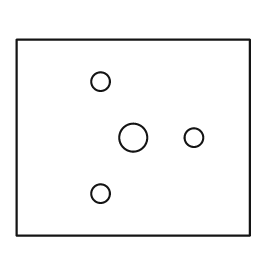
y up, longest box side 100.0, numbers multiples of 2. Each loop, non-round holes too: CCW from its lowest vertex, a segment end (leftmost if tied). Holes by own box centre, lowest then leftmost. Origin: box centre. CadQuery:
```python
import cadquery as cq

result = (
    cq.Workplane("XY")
    .moveTo(-50.0, -42.0)
    .lineTo(50.0, -42.0)
    .lineTo(50.0, 42.0)
    .lineTo(-50.0, 42.0)
    .close()
    .moveTo(-14.0, -24.0)
    .circle(4.0)
    .moveTo(0.0, 0.0)
    .circle(6.0)
    .moveTo(26.0, 0.0)
    .circle(4.0)
    .moveTo(-14.0, 24.0)
    .circle(4.0)
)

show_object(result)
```